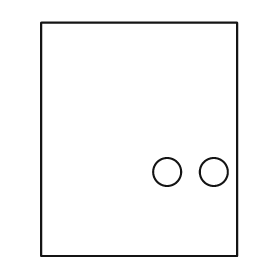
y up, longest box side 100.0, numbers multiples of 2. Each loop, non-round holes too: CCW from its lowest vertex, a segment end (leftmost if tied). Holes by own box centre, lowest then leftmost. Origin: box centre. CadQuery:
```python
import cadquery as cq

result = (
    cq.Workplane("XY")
    .moveTo(-42.0, -50.0)
    .lineTo(42.0, -50.0)
    .lineTo(42.0, 50.0)
    .lineTo(-42.0, 50.0)
    .close()
    .moveTo(12.0, -14.0)
    .circle(6.0)
    .moveTo(32.0, -14.0)
    .circle(6.0)
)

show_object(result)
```